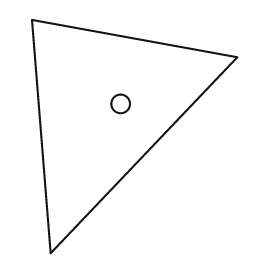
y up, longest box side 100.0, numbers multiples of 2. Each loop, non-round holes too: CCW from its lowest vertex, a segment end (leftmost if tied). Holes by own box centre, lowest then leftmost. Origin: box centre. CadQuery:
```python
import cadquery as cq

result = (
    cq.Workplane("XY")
    .moveTo(-36.0, -50.0)
    .lineTo(44.0, 34.0)
    .lineTo(-44.0, 50.0)
    .close()
    .moveTo(-6.0, 14.0)
    .circle(4.0)
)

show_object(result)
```